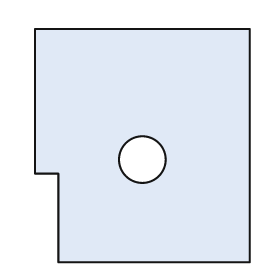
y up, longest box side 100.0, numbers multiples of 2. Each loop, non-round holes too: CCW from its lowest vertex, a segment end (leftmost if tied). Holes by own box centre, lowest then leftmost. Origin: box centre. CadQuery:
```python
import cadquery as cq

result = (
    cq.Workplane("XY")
    .moveTo(-36.0, -50.0)
    .lineTo(46.0, -50.0)
    .lineTo(46.0, 50.0)
    .lineTo(-46.0, 50.0)
    .lineTo(-46.0, -12.0)
    .lineTo(-36.0, -12.0)
    .close()
    .moveTo(0.0, -6.0)
    .circle(10.0)
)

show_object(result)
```